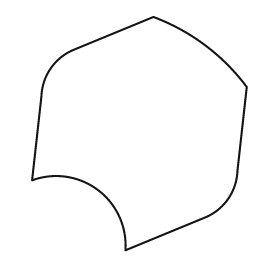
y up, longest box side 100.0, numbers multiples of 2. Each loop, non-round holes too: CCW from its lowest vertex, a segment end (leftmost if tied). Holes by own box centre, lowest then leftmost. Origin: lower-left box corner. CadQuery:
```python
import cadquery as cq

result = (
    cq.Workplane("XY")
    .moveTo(40.0, 0.0)
    .lineTo(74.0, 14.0)
    .threePointArc((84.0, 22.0), (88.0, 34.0))
    .lineTo(92.0, 70.0)
    .threePointArc((74.0, 88.0), (52.0, 100.0))
    .lineTo(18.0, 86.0)
    .threePointArc((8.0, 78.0), (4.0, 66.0))
    .lineTo(0.0, 30.0)
    .threePointArc((28.0, 26.0), (40.0, 0.0))
    .close()
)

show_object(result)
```